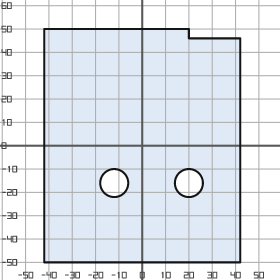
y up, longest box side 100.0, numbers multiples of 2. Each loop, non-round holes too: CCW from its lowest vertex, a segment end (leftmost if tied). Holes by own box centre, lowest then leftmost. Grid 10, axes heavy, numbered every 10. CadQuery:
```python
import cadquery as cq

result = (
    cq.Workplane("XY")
    .moveTo(-42.0, -50.0)
    .lineTo(42.0, -50.0)
    .lineTo(42.0, 46.0)
    .lineTo(20.0, 46.0)
    .lineTo(20.0, 50.0)
    .lineTo(-42.0, 50.0)
    .close()
    .moveTo(-12.0, -16.0)
    .circle(6.0)
    .moveTo(20.0, -16.0)
    .circle(6.0)
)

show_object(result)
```